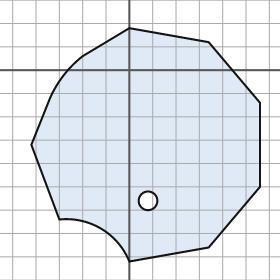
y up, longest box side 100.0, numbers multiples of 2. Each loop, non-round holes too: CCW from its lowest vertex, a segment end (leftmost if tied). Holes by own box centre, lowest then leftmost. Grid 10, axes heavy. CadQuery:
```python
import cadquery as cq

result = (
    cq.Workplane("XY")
    .moveTo(0.0, -82.0)
    .lineTo(34.0, -76.0)
    .lineTo(56.0, -50.0)
    .lineTo(56.0, -14.0)
    .lineTo(34.0, 12.0)
    .lineTo(0.0, 18.0)
    .lineTo(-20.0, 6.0)
    .threePointArc((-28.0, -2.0), (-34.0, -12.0))
    .lineTo(-42.0, -32.0)
    .lineTo(-30.0, -64.0)
    .threePointArc((-12.0, -68.0), (0.0, -82.0))
    .close()
    .moveTo(8.0, -56.0)
    .circle(4.0)
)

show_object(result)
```